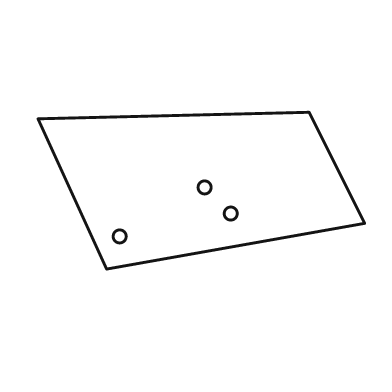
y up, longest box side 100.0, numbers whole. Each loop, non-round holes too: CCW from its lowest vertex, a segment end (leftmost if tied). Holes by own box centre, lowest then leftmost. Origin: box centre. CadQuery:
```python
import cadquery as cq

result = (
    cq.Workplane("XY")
    .moveTo(-29.0, -24.0)
    .lineTo(50.0, -10.0)
    .lineTo(33.0, 24.0)
    .lineTo(-50.0, 22.0)
    .close()
    .moveTo(-25.0, -14.0)
    .circle(2.0)
    .moveTo(9.0, -7.0)
    .circle(2.0)
    .moveTo(1.0, 1.0)
    .circle(2.0)
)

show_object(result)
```